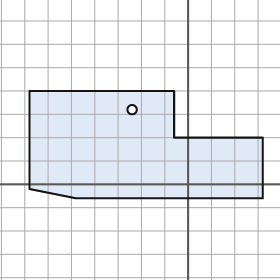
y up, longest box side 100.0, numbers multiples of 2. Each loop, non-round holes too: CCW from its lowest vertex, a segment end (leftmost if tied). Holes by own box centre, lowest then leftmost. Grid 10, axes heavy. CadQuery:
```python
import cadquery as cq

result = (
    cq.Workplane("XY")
    .moveTo(-48.0, -6.0)
    .lineTo(32.0, -6.0)
    .lineTo(32.0, 20.0)
    .lineTo(-6.0, 20.0)
    .lineTo(-6.0, 40.0)
    .lineTo(-68.0, 40.0)
    .lineTo(-68.0, -2.0)
    .close()
    .moveTo(-24.0, 32.0)
    .circle(2.0)
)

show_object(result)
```